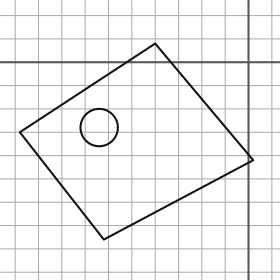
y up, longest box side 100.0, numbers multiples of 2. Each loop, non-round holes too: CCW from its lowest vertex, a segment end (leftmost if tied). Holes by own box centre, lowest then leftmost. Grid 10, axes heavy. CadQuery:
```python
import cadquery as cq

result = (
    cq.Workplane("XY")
    .moveTo(-62.0, -76.0)
    .lineTo(2.0, -42.0)
    .lineTo(-40.0, 8.0)
    .lineTo(-98.0, -30.0)
    .close()
    .moveTo(-64.0, -28.0)
    .circle(8.0)
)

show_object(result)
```